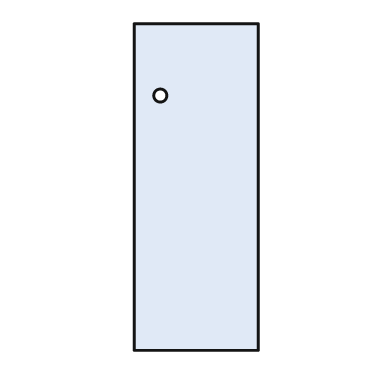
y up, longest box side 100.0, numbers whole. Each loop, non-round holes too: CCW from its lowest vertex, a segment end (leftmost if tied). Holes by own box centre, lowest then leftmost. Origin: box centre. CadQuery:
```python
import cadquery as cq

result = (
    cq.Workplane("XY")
    .moveTo(-19.0, -50.0)
    .lineTo(19.0, -50.0)
    .lineTo(19.0, 50.0)
    .lineTo(-19.0, 50.0)
    .close()
    .moveTo(-11.0, 28.0)
    .circle(2.0)
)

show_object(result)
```